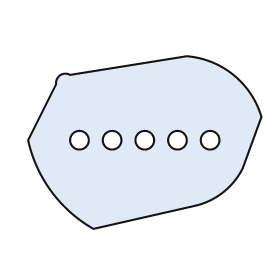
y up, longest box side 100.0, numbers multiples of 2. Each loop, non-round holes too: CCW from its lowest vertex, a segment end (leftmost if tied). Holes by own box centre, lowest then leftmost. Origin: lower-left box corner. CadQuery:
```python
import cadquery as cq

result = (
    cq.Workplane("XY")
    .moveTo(28.0, 0.0)
    .lineTo(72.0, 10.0)
    .threePointArc((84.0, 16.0), (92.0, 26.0))
    .lineTo(100.0, 48.0)
    .threePointArc((88.0, 66.0), (68.0, 74.0))
    .lineTo(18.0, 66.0)
    .threePointArc((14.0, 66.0), (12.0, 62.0))
    .lineTo(0.0, 38.0)
    .threePointArc((10.0, 16.0), (28.0, 0.0))
    .close()
    .moveTo(22.0, 38.0)
    .circle(4.0)
    .moveTo(36.0, 38.0)
    .circle(4.0)
    .moveTo(50.0, 38.0)
    .circle(4.0)
    .moveTo(64.0, 38.0)
    .circle(4.0)
    .moveTo(78.0, 38.0)
    .circle(4.0)
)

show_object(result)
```